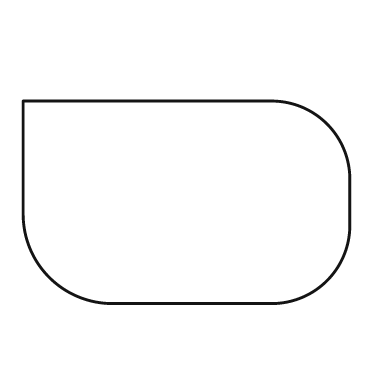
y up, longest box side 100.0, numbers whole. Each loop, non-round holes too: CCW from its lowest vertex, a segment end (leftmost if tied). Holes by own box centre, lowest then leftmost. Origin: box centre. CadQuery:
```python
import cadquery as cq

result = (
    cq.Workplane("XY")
    .moveTo(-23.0, -31.0)
    .lineTo(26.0, -31.0)
    .threePointArc((43.0, -24.0), (50.0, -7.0))
    .lineTo(50.0, 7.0)
    .threePointArc((43.0, 24.0), (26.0, 31.0))
    .lineTo(-50.0, 31.0)
    .lineTo(-50.0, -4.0)
    .threePointArc((-42.0, -23.0), (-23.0, -31.0))
    .close()
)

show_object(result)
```